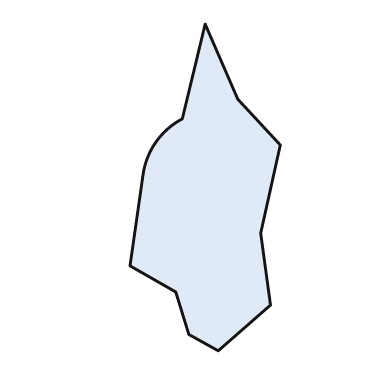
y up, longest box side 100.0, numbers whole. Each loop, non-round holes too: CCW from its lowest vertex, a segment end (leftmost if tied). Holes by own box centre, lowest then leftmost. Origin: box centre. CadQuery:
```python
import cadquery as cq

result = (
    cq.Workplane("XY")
    .moveTo(4.0, -50.0)
    .lineTo(20.0, -36.0)
    .lineTo(17.0, -14.0)
    .lineTo(23.0, 13.0)
    .lineTo(10.0, 27.0)
    .lineTo(0.0, 50.0)
    .lineTo(-7.0, 21.0)
    .threePointArc((-15.0, 14.0), (-19.0, 4.0))
    .lineTo(-23.0, -24.0)
    .lineTo(-9.0, -32.0)
    .lineTo(-5.0, -45.0)
    .close()
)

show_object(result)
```